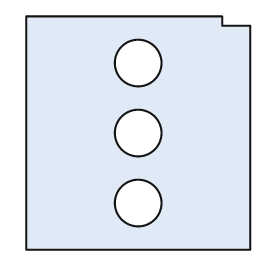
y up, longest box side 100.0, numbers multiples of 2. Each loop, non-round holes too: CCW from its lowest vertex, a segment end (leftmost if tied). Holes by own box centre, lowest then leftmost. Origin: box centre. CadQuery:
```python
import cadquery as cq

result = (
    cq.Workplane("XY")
    .moveTo(-48.0, -50.0)
    .lineTo(48.0, -50.0)
    .lineTo(48.0, 46.0)
    .lineTo(36.0, 46.0)
    .lineTo(36.0, 50.0)
    .lineTo(-48.0, 50.0)
    .close()
    .moveTo(0.0, -30.0)
    .circle(10.0)
    .moveTo(0.0, 0.0)
    .circle(10.0)
    .moveTo(0.0, 30.0)
    .circle(10.0)
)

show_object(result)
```